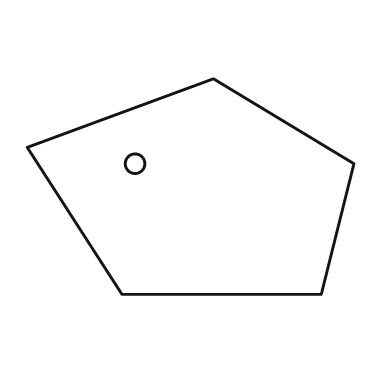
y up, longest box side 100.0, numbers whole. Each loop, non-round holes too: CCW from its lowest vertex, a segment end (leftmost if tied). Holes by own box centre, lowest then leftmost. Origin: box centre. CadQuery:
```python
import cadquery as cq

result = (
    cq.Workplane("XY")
    .moveTo(-21.0, -33.0)
    .lineTo(40.0, -33.0)
    .lineTo(50.0, 7.0)
    .lineTo(7.0, 33.0)
    .lineTo(-50.0, 12.0)
    .close()
    .moveTo(-17.0, 7.0)
    .circle(3.0)
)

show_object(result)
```